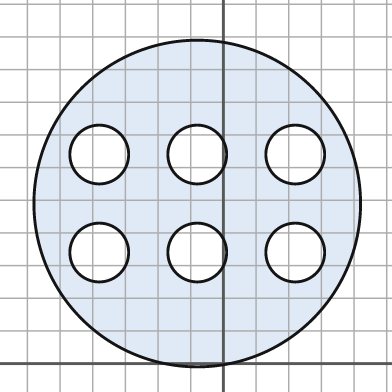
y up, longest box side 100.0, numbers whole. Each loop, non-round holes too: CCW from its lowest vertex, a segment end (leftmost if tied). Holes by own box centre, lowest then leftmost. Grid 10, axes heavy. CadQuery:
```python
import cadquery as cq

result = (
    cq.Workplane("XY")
    .moveTo(-8.0, 49.0)
    .circle(50.0)
    .moveTo(-38.0, 34.0)
    .circle(9.0)
    .moveTo(-8.0, 34.0)
    .circle(9.0)
    .moveTo(22.0, 34.0)
    .circle(9.0)
    .moveTo(-38.0, 64.0)
    .circle(9.0)
    .moveTo(-8.0, 64.0)
    .circle(9.0)
    .moveTo(22.0, 64.0)
    .circle(9.0)
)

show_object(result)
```